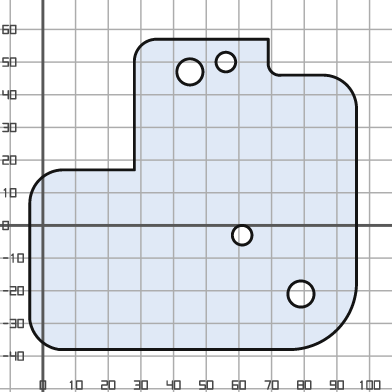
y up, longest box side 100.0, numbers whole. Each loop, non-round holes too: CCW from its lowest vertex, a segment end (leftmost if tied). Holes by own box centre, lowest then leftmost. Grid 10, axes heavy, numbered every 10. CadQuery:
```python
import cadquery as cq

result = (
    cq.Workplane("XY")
    .moveTo(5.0, -38.0)
    .lineTo(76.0, -38.0)
    .threePointArc((90.0, -32.0), (96.0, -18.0))
    .lineTo(96.0, 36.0)
    .threePointArc((93.0, 43.0), (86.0, 46.0))
    .lineTo(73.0, 46.0)
    .threePointArc((70.0, 47.0), (69.0, 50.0))
    .lineTo(69.0, 57.0)
    .lineTo(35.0, 57.0)
    .threePointArc((30.0, 55.0), (28.0, 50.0))
    .lineTo(28.0, 17.0)
    .lineTo(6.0, 17.0)
    .threePointArc((-1.0, 14.0), (-4.0, 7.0))
    .lineTo(-4.0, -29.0)
    .threePointArc((-1.0, -35.0), (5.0, -38.0))
    .close()
    .moveTo(79.0, -21.0)
    .circle(4.0)
    .moveTo(61.0, -3.0)
    .circle(3.0)
    .moveTo(45.0, 47.0)
    .circle(4.0)
    .moveTo(56.0, 50.0)
    .circle(3.0)
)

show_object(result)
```